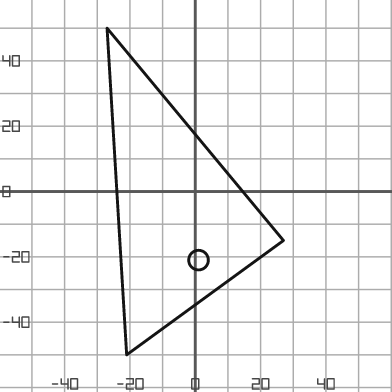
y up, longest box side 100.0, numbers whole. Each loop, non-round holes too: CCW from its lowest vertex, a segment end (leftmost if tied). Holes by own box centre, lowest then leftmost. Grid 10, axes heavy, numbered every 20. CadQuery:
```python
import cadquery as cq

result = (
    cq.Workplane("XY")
    .moveTo(-21.0, -50.0)
    .lineTo(27.0, -15.0)
    .lineTo(-27.0, 50.0)
    .close()
    .moveTo(1.0, -21.0)
    .circle(3.0)
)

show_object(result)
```